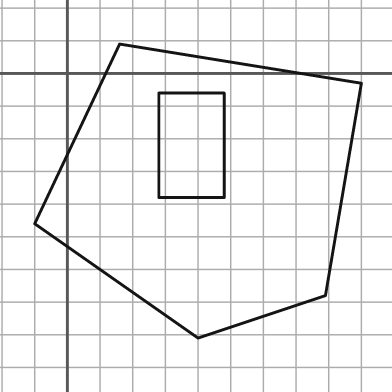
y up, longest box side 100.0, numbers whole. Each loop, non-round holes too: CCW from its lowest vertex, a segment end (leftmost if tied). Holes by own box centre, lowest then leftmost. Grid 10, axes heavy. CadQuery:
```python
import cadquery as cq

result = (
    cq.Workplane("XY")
    .moveTo(40.0, -81.0)
    .lineTo(79.0, -68.0)
    .lineTo(90.0, -3.0)
    .lineTo(16.0, 9.0)
    .lineTo(-10.0, -46.0)
    .close()
    .moveTo(28.0, -38.0)
    .lineTo(48.0, -38.0)
    .lineTo(48.0, -6.0)
    .lineTo(28.0, -6.0)
    .close()
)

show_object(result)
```